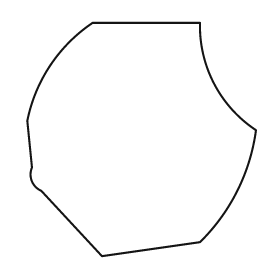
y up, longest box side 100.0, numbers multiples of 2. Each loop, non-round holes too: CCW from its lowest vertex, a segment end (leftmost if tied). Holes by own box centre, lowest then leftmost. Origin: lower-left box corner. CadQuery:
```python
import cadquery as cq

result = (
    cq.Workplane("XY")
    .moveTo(32.0, 0.0)
    .lineTo(74.0, 6.0)
    .threePointArc((90.0, 28.0), (98.0, 54.0))
    .threePointArc((80.0, 74.0), (74.0, 100.0))
    .lineTo(28.0, 100.0)
    .threePointArc((10.0, 82.0), (0.0, 58.0))
    .lineTo(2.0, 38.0)
    .threePointArc((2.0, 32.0), (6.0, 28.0))
    .close()
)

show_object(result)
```